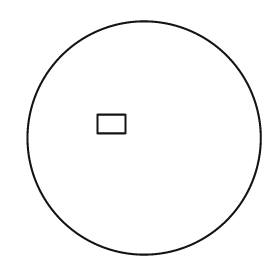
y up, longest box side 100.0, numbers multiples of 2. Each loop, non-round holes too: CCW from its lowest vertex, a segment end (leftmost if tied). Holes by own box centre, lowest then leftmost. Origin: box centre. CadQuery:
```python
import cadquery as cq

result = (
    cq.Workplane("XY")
    .moveTo(0.0, 0.0)
    .circle(50.0)
    .moveTo(-20.0, 2.0)
    .lineTo(-8.0, 2.0)
    .lineTo(-8.0, 10.0)
    .lineTo(-20.0, 10.0)
    .close()
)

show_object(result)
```